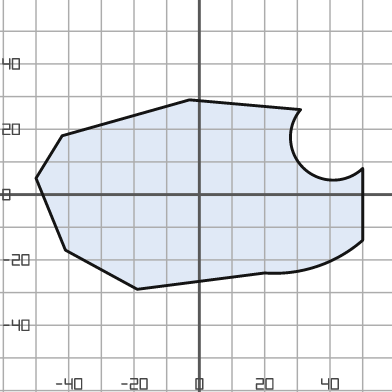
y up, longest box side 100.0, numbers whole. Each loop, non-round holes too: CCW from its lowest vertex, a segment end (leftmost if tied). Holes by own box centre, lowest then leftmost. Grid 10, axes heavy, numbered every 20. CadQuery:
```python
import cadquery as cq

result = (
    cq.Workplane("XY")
    .moveTo(-19.0, -29.0)
    .lineTo(20.0, -24.0)
    .threePointArc((36.0, -22.0), (50.0, -14.0))
    .lineTo(50.0, 8.0)
    .threePointArc((32.0, 8.0), (31.0, 26.0))
    .lineTo(-3.0, 29.0)
    .lineTo(-42.0, 18.0)
    .lineTo(-50.0, 5.0)
    .lineTo(-41.0, -17.0)
    .close()
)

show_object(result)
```